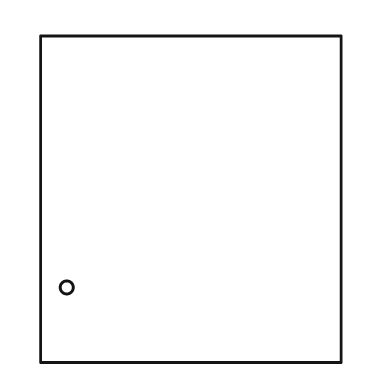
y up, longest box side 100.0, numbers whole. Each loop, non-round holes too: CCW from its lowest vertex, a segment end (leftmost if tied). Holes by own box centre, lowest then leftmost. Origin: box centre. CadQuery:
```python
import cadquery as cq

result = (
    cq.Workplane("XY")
    .moveTo(-46.0, -50.0)
    .lineTo(46.0, -50.0)
    .lineTo(46.0, 50.0)
    .lineTo(-46.0, 50.0)
    .close()
    .moveTo(-38.0, -27.0)
    .circle(2.0)
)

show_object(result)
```